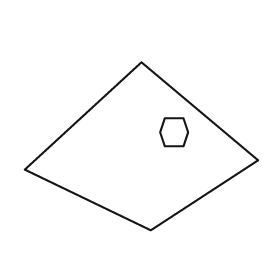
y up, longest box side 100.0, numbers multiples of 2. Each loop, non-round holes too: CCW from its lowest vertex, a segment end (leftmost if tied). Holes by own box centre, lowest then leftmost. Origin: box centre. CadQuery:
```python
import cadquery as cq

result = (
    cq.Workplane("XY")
    .moveTo(4.0, -36.0)
    .lineTo(50.0, -6.0)
    .lineTo(0.0, 36.0)
    .lineTo(-50.0, -10.0)
    .close()
    .moveTo(10.0, 0.0)
    .lineTo(18.0, 0.0)
    .lineTo(20.0, 6.0)
    .lineTo(18.0, 12.0)
    .lineTo(10.0, 12.0)
    .lineTo(8.0, 6.0)
    .close()
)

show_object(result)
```